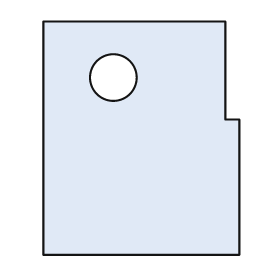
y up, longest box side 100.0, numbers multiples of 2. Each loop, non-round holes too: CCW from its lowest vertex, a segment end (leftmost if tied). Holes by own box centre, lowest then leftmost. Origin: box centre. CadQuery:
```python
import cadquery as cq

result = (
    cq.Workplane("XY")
    .moveTo(-42.0, -50.0)
    .lineTo(42.0, -50.0)
    .lineTo(42.0, 8.0)
    .lineTo(36.0, 8.0)
    .lineTo(36.0, 50.0)
    .lineTo(-42.0, 50.0)
    .close()
    .moveTo(-12.0, 26.0)
    .circle(10.0)
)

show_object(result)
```